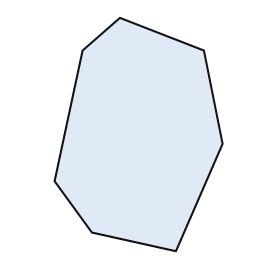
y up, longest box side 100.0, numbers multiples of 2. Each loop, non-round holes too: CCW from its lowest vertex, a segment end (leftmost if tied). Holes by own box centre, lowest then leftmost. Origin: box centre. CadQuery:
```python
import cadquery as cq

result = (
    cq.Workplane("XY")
    .moveTo(16.0, -50.0)
    .lineTo(36.0, -4.0)
    .lineTo(28.0, 36.0)
    .lineTo(-8.0, 50.0)
    .lineTo(-24.0, 36.0)
    .lineTo(-36.0, -20.0)
    .lineTo(-20.0, -42.0)
    .close()
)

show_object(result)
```